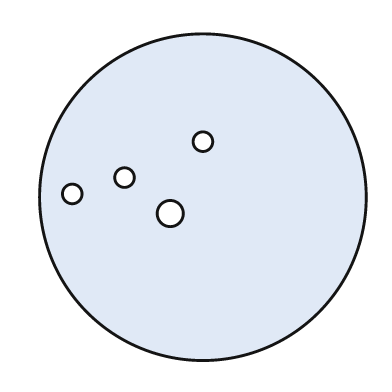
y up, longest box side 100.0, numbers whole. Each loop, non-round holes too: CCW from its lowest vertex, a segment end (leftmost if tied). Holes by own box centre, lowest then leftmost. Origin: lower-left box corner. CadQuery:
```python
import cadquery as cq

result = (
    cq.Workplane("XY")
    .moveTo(50.0, 50.0)
    .circle(50.0)
    .moveTo(40.0, 45.0)
    .circle(4.0)
    .moveTo(10.0, 51.0)
    .circle(3.0)
    .moveTo(26.0, 56.0)
    .circle(3.0)
    .moveTo(50.0, 67.0)
    .circle(3.0)
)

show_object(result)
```